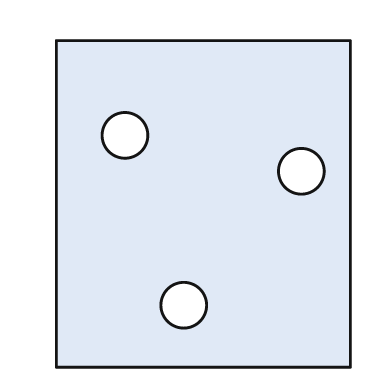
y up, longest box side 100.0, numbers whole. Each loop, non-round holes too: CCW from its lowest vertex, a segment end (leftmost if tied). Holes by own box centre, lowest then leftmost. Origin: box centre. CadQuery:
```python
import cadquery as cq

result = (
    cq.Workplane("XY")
    .moveTo(-45.0, -50.0)
    .lineTo(45.0, -50.0)
    .lineTo(45.0, 50.0)
    .lineTo(-45.0, 50.0)
    .close()
    .moveTo(-6.0, -31.0)
    .circle(7.0)
    .moveTo(30.0, 10.0)
    .circle(7.0)
    .moveTo(-24.0, 21.0)
    .circle(7.0)
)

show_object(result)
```